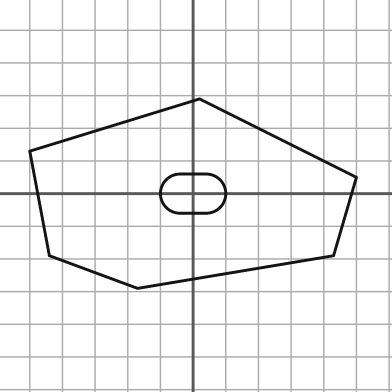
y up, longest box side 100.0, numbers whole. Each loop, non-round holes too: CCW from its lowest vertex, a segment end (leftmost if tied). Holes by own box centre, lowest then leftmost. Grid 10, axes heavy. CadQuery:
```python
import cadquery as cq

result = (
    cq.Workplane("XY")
    .moveTo(-17.0, -29.0)
    .lineTo(43.0, -19.0)
    .lineTo(50.0, 5.0)
    .lineTo(2.0, 29.0)
    .lineTo(-50.0, 13.0)
    .lineTo(-44.0, -19.0)
    .close()
    .moveTo(-4.0, -6.0)
    .lineTo(4.0, -6.0)
    .threePointArc((10.0, 0.0), (4.0, 6.0))
    .lineTo(-4.0, 6.0)
    .threePointArc((-10.0, 0.0), (-4.0, -6.0))
    .close()
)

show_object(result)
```